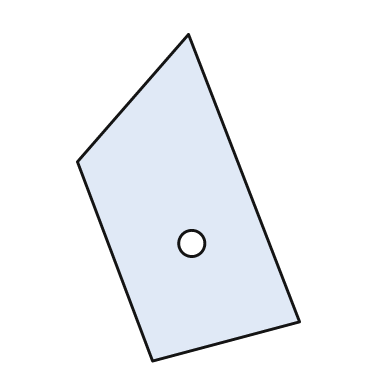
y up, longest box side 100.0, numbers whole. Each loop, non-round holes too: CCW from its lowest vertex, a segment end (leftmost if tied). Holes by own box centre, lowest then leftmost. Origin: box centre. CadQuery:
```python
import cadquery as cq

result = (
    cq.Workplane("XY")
    .moveTo(-11.0, -50.0)
    .lineTo(34.0, -38.0)
    .lineTo(0.0, 50.0)
    .lineTo(-34.0, 11.0)
    .close()
    .moveTo(1.0, -14.0)
    .circle(4.0)
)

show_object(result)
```